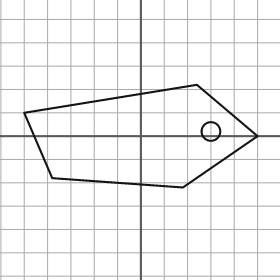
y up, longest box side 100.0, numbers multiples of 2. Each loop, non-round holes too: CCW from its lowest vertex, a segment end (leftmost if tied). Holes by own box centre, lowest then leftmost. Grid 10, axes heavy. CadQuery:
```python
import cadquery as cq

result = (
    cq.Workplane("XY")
    .moveTo(18.0, -22.0)
    .lineTo(50.0, 0.0)
    .lineTo(24.0, 22.0)
    .lineTo(-50.0, 10.0)
    .lineTo(-38.0, -18.0)
    .close()
    .moveTo(30.0, 2.0)
    .circle(4.0)
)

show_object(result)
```